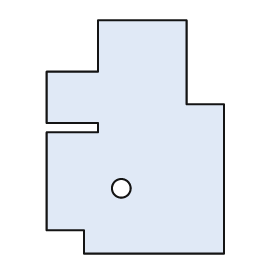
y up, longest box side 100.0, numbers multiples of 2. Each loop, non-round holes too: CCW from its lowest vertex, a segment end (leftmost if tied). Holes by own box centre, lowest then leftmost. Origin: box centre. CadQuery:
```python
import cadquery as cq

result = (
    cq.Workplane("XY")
    .moveTo(-22.0, -50.0)
    .lineTo(38.0, -50.0)
    .lineTo(38.0, 14.0)
    .lineTo(22.0, 14.0)
    .lineTo(22.0, 50.0)
    .lineTo(-16.0, 50.0)
    .lineTo(-16.0, 28.0)
    .lineTo(-38.0, 28.0)
    .lineTo(-38.0, 6.0)
    .lineTo(-16.0, 6.0)
    .lineTo(-16.0, 2.0)
    .lineTo(-38.0, 2.0)
    .lineTo(-38.0, -40.0)
    .lineTo(-22.0, -40.0)
    .close()
    .moveTo(-6.0, -22.0)
    .circle(4.0)
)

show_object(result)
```